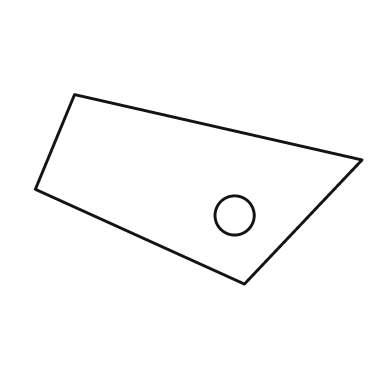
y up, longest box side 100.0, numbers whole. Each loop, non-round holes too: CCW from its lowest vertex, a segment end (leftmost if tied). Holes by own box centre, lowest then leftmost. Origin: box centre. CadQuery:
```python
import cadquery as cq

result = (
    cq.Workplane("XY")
    .moveTo(14.0, -29.0)
    .lineTo(50.0, 9.0)
    .lineTo(-38.0, 29.0)
    .lineTo(-50.0, 0.0)
    .close()
    .moveTo(11.0, -8.0)
    .circle(6.0)
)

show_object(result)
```